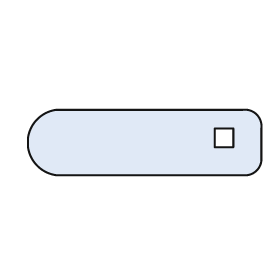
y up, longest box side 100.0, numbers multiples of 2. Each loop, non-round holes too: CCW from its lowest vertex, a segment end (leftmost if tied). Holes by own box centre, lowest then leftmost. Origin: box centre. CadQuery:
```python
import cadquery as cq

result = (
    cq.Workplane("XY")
    .moveTo(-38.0, -14.0)
    .lineTo(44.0, -14.0)
    .threePointArc((48.0, -12.0), (50.0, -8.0))
    .lineTo(50.0, 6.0)
    .threePointArc((48.0, 12.0), (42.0, 14.0))
    .lineTo(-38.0, 14.0)
    .threePointArc((-46.0, 10.0), (-50.0, 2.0))
    .lineTo(-50.0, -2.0)
    .threePointArc((-46.0, -10.0), (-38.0, -14.0))
    .close()
    .moveTo(30.0, -2.0)
    .lineTo(38.0, -2.0)
    .lineTo(38.0, 6.0)
    .lineTo(30.0, 6.0)
    .close()
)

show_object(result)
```